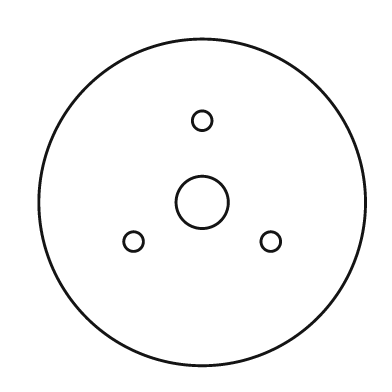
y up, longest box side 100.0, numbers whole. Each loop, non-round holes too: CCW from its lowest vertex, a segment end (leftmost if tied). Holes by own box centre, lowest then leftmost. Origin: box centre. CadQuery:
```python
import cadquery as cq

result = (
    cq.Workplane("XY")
    .moveTo(0.0, 0.0)
    .circle(50.0)
    .moveTo(-21.0, -12.0)
    .circle(3.0)
    .moveTo(21.0, -12.0)
    .circle(3.0)
    .moveTo(0.0, 0.0)
    .circle(8.0)
    .moveTo(0.0, 25.0)
    .circle(3.0)
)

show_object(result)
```